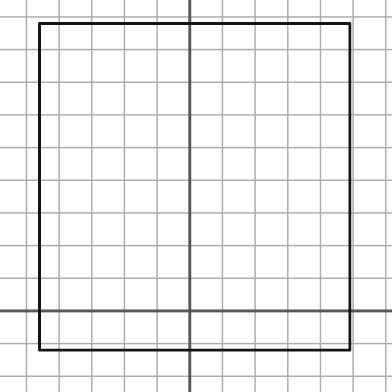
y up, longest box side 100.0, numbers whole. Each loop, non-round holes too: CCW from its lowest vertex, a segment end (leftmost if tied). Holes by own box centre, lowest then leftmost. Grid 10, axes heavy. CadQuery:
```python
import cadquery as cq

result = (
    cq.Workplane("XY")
    .moveTo(-46.0, -12.0)
    .lineTo(49.0, -12.0)
    .lineTo(49.0, 88.0)
    .lineTo(-46.0, 88.0)
    .close()
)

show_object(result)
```